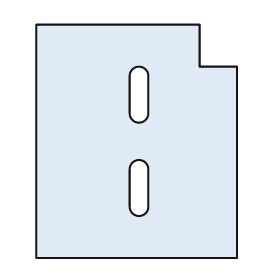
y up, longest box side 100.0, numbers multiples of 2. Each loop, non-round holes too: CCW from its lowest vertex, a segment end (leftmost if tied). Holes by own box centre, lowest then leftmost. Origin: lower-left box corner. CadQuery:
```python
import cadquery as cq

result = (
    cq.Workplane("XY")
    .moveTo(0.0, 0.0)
    .lineTo(86.0, 0.0)
    .lineTo(86.0, 82.0)
    .lineTo(70.0, 82.0)
    .lineTo(70.0, 100.0)
    .lineTo(0.0, 100.0)
    .close()
    .moveTo(40.0, 22.0)
    .threePointArc((44.0, 18.0), (48.0, 22.0))
    .lineTo(48.0, 38.0)
    .threePointArc((44.0, 42.0), (40.0, 38.0))
    .close()
    .moveTo(40.0, 62.0)
    .threePointArc((44.0, 58.0), (48.0, 62.0))
    .lineTo(48.0, 78.0)
    .threePointArc((44.0, 82.0), (40.0, 78.0))
    .close()
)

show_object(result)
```